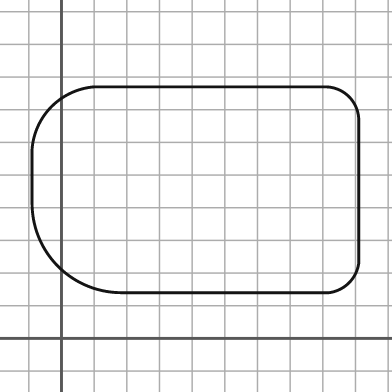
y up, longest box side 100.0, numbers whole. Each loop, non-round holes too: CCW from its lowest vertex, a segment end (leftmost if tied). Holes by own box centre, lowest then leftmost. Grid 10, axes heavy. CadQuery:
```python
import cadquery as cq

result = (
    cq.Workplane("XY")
    .moveTo(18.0, 14.0)
    .lineTo(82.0, 14.0)
    .threePointArc((88.0, 17.0), (91.0, 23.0))
    .lineTo(91.0, 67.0)
    .threePointArc((88.0, 74.0), (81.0, 77.0))
    .lineTo(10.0, 77.0)
    .threePointArc((-3.0, 71.0), (-9.0, 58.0))
    .lineTo(-9.0, 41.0)
    .threePointArc((-1.0, 22.0), (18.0, 14.0))
    .close()
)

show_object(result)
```